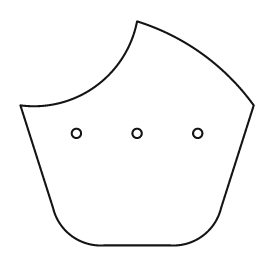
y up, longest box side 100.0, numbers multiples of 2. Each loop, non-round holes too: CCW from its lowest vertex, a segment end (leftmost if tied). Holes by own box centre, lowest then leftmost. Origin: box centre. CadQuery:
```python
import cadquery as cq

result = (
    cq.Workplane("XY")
    .moveTo(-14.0, -48.0)
    .lineTo(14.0, -48.0)
    .threePointArc((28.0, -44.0), (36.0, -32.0))
    .lineTo(50.0, 12.0)
    .threePointArc((28.0, 34.0), (0.0, 48.0))
    .threePointArc((-18.0, 20.0), (-50.0, 12.0))
    .lineTo(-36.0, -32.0)
    .threePointArc((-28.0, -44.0), (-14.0, -48.0))
    .close()
    .moveTo(-26.0, 0.0)
    .circle(2.0)
    .moveTo(0.0, 0.0)
    .circle(2.0)
    .moveTo(26.0, 0.0)
    .circle(2.0)
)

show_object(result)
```